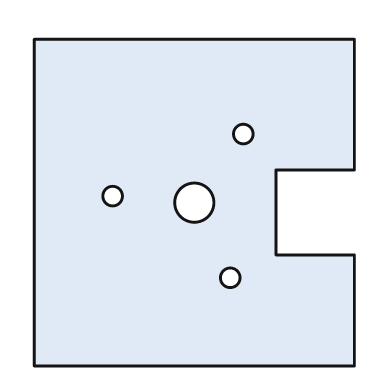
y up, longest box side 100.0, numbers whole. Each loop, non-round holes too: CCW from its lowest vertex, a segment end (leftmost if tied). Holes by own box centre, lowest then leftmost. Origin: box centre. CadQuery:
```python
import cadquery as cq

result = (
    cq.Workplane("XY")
    .moveTo(-49.0, -50.0)
    .lineTo(49.0, -50.0)
    .lineTo(49.0, -16.0)
    .lineTo(25.0, -16.0)
    .lineTo(25.0, 10.0)
    .lineTo(49.0, 10.0)
    .lineTo(49.0, 50.0)
    .lineTo(-49.0, 50.0)
    .close()
    .moveTo(11.0, -23.0)
    .circle(3.0)
    .moveTo(0.0, 0.0)
    .circle(6.0)
    .moveTo(-25.0, 2.0)
    .circle(3.0)
    .moveTo(15.0, 21.0)
    .circle(3.0)
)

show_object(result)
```